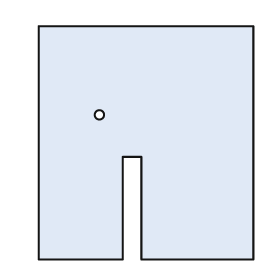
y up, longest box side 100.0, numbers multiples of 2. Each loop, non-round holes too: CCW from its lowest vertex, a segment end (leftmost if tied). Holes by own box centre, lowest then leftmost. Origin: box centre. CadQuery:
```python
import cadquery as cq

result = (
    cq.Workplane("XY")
    .moveTo(-46.0, -50.0)
    .lineTo(-10.0, -50.0)
    .lineTo(-10.0, -6.0)
    .lineTo(-2.0, -6.0)
    .lineTo(-2.0, -50.0)
    .lineTo(46.0, -50.0)
    .lineTo(46.0, 50.0)
    .lineTo(-46.0, 50.0)
    .close()
    .moveTo(-20.0, 12.0)
    .circle(2.0)
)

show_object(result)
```